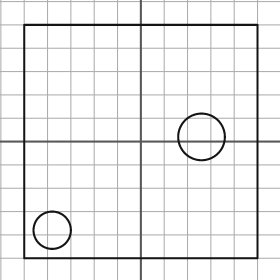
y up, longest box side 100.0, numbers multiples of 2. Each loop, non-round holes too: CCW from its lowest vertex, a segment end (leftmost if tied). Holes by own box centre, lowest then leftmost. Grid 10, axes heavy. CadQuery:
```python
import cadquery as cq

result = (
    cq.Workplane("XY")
    .moveTo(-50.0, -50.0)
    .lineTo(50.0, -50.0)
    .lineTo(50.0, 50.0)
    .lineTo(-50.0, 50.0)
    .close()
    .moveTo(-38.0, -38.0)
    .circle(8.0)
    .moveTo(26.0, 2.0)
    .circle(10.0)
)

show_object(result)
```